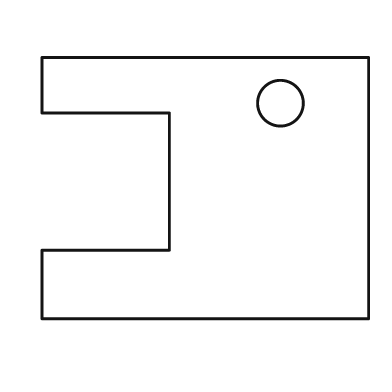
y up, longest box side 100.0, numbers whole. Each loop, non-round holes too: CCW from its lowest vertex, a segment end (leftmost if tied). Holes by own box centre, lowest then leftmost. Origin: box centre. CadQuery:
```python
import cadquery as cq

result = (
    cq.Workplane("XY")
    .moveTo(-50.0, -40.0)
    .lineTo(50.0, -40.0)
    .lineTo(50.0, 40.0)
    .lineTo(-50.0, 40.0)
    .lineTo(-50.0, 23.0)
    .lineTo(-11.0, 23.0)
    .lineTo(-11.0, -19.0)
    .lineTo(-50.0, -19.0)
    .close()
    .moveTo(23.0, 26.0)
    .circle(7.0)
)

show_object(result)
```